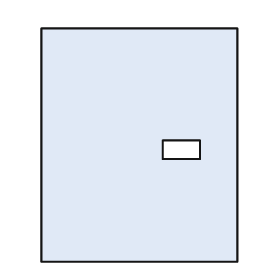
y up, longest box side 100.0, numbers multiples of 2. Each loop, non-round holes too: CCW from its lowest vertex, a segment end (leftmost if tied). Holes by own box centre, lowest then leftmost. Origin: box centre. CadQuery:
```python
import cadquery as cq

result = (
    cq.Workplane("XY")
    .moveTo(-42.0, -50.0)
    .lineTo(42.0, -50.0)
    .lineTo(42.0, 50.0)
    .lineTo(-42.0, 50.0)
    .close()
    .moveTo(10.0, -6.0)
    .lineTo(26.0, -6.0)
    .lineTo(26.0, 2.0)
    .lineTo(10.0, 2.0)
    .close()
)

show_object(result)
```